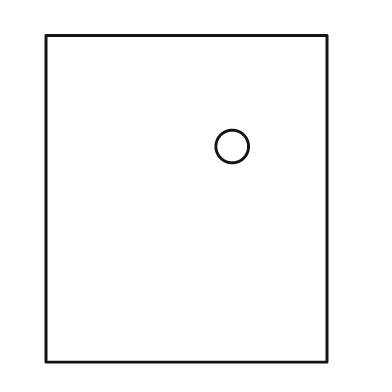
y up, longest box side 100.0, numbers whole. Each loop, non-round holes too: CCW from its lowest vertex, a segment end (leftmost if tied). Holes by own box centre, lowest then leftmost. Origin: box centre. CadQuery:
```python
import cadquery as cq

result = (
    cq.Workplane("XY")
    .moveTo(-43.0, -50.0)
    .lineTo(43.0, -50.0)
    .lineTo(43.0, 50.0)
    .lineTo(-43.0, 50.0)
    .close()
    .moveTo(14.0, 16.0)
    .circle(5.0)
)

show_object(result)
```